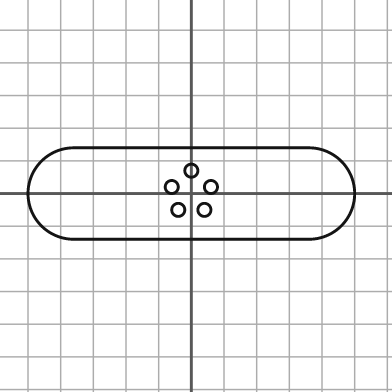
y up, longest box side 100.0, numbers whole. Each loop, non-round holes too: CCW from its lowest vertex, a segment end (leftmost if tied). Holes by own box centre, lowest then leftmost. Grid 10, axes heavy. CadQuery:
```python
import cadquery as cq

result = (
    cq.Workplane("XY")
    .moveTo(-36.0, -14.0)
    .lineTo(36.0, -14.0)
    .threePointArc((50.0, 0.0), (36.0, 14.0))
    .lineTo(-36.0, 14.0)
    .threePointArc((-50.0, 0.0), (-36.0, -14.0))
    .close()
    .moveTo(-4.0, -5.0)
    .circle(2.0)
    .moveTo(4.0, -5.0)
    .circle(2.0)
    .moveTo(-6.0, 2.0)
    .circle(2.0)
    .moveTo(6.0, 2.0)
    .circle(2.0)
    .moveTo(0.0, 7.0)
    .circle(2.0)
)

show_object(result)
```